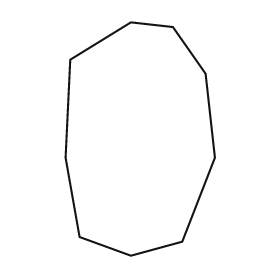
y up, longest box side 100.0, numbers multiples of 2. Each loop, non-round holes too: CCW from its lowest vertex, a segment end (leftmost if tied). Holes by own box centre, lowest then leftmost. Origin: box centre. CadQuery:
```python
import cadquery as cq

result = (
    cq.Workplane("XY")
    .moveTo(-4.0, -50.0)
    .lineTo(18.0, -44.0)
    .lineTo(32.0, -8.0)
    .lineTo(28.0, 28.0)
    .lineTo(14.0, 48.0)
    .lineTo(-4.0, 50.0)
    .lineTo(-30.0, 34.0)
    .lineTo(-32.0, -8.0)
    .lineTo(-26.0, -42.0)
    .close()
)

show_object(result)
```